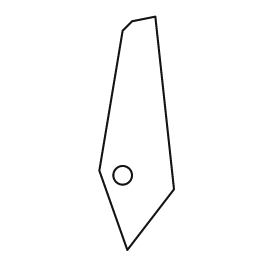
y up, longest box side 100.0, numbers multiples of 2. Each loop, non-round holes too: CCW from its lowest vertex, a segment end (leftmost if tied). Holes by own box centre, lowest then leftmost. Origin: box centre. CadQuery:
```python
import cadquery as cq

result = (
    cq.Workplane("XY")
    .moveTo(-4.0, -50.0)
    .lineTo(16.0, -24.0)
    .lineTo(8.0, 50.0)
    .lineTo(-2.0, 48.0)
    .lineTo(-6.0, 44.0)
    .lineTo(-16.0, -16.0)
    .close()
    .moveTo(-6.0, -18.0)
    .circle(4.0)
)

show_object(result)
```